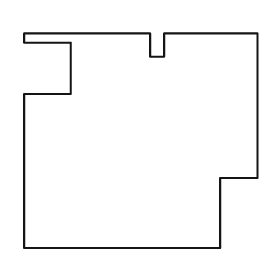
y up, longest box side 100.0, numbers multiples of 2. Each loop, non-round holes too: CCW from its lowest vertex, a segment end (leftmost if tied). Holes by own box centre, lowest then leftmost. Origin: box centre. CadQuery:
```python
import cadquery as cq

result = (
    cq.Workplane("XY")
    .moveTo(-50.0, -46.0)
    .lineTo(34.0, -46.0)
    .lineTo(34.0, -16.0)
    .lineTo(50.0, -16.0)
    .lineTo(50.0, 46.0)
    .lineTo(10.0, 46.0)
    .lineTo(10.0, 36.0)
    .lineTo(4.0, 36.0)
    .lineTo(4.0, 46.0)
    .lineTo(-50.0, 46.0)
    .lineTo(-50.0, 42.0)
    .lineTo(-30.0, 42.0)
    .lineTo(-30.0, 20.0)
    .lineTo(-50.0, 20.0)
    .close()
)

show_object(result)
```